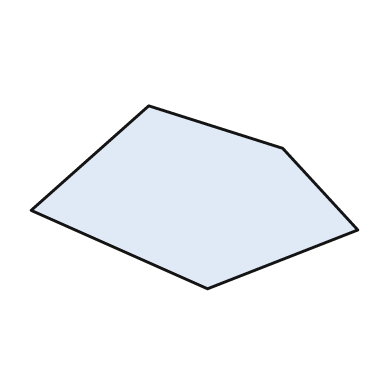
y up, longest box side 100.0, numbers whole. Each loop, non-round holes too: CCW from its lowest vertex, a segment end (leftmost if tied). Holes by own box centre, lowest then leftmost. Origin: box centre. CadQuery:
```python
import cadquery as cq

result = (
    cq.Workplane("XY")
    .moveTo(4.0, -28.0)
    .lineTo(50.0, -10.0)
    .lineTo(27.0, 15.0)
    .lineTo(-14.0, 28.0)
    .lineTo(-50.0, -4.0)
    .close()
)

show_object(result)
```